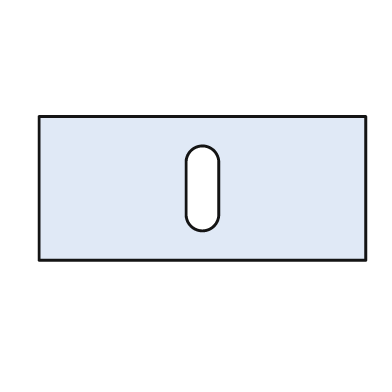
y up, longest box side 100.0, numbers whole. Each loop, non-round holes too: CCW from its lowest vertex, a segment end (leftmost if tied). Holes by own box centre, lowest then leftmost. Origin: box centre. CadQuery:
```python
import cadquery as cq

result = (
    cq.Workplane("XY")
    .moveTo(-50.0, -22.0)
    .lineTo(50.0, -22.0)
    .lineTo(50.0, 22.0)
    .lineTo(-50.0, 22.0)
    .close()
    .moveTo(-5.0, -8.0)
    .threePointArc((0.0, -13.0), (5.0, -8.0))
    .lineTo(5.0, 8.0)
    .threePointArc((0.0, 13.0), (-5.0, 8.0))
    .close()
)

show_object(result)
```